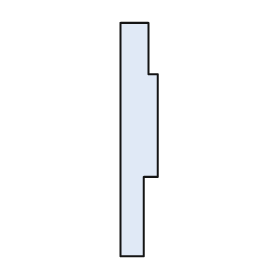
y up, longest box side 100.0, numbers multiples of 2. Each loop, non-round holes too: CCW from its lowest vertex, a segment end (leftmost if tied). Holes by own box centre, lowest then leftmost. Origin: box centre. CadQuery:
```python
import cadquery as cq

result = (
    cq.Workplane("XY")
    .moveTo(-8.0, -50.0)
    .lineTo(2.0, -50.0)
    .lineTo(2.0, -16.0)
    .lineTo(8.0, -16.0)
    .lineTo(8.0, 28.0)
    .lineTo(4.0, 28.0)
    .lineTo(4.0, 50.0)
    .lineTo(-8.0, 50.0)
    .close()
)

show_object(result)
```